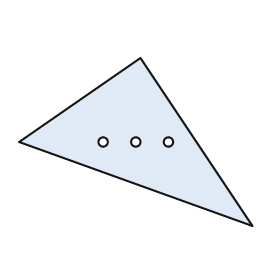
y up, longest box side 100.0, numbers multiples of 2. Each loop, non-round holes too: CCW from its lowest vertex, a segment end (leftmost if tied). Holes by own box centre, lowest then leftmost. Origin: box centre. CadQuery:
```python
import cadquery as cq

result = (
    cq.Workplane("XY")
    .moveTo(50.0, -36.0)
    .lineTo(2.0, 36.0)
    .lineTo(-50.0, 0.0)
    .close()
    .moveTo(-14.0, 0.0)
    .circle(2.0)
    .moveTo(0.0, 0.0)
    .circle(2.0)
    .moveTo(14.0, 0.0)
    .circle(2.0)
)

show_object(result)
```